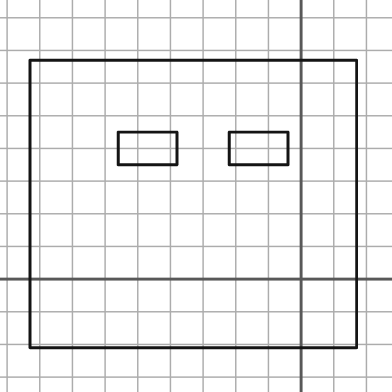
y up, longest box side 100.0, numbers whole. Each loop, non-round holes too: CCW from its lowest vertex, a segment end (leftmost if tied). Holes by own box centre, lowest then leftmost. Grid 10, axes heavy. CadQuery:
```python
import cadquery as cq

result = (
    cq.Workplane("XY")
    .moveTo(-83.0, -21.0)
    .lineTo(17.0, -21.0)
    .lineTo(17.0, 67.0)
    .lineTo(-83.0, 67.0)
    .close()
    .moveTo(-56.0, 35.0)
    .lineTo(-38.0, 35.0)
    .lineTo(-38.0, 45.0)
    .lineTo(-56.0, 45.0)
    .close()
    .moveTo(-22.0, 35.0)
    .lineTo(-4.0, 35.0)
    .lineTo(-4.0, 45.0)
    .lineTo(-22.0, 45.0)
    .close()
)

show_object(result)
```